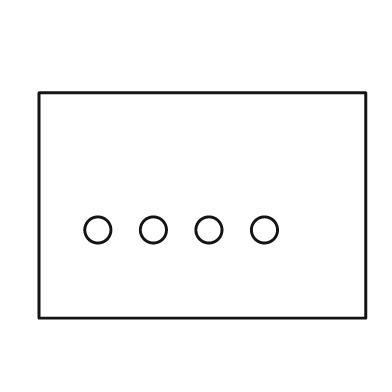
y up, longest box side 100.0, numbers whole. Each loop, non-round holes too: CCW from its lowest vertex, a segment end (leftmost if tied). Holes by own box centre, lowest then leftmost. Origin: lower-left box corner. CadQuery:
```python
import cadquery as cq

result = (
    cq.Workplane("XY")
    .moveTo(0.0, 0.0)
    .lineTo(100.0, 0.0)
    .lineTo(100.0, 69.0)
    .lineTo(0.0, 69.0)
    .close()
    .moveTo(18.0, 27.0)
    .circle(4.0)
    .moveTo(35.0, 27.0)
    .circle(4.0)
    .moveTo(52.0, 27.0)
    .circle(4.0)
    .moveTo(69.0, 27.0)
    .circle(4.0)
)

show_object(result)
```